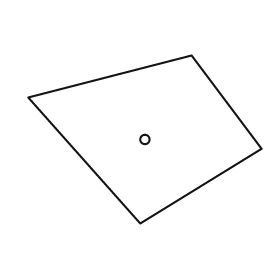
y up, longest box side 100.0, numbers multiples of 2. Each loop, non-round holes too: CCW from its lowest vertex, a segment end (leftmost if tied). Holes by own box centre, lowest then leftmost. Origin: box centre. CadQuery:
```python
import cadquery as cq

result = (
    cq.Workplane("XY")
    .moveTo(-2.0, -36.0)
    .lineTo(50.0, -4.0)
    .lineTo(20.0, 36.0)
    .lineTo(-50.0, 18.0)
    .close()
    .moveTo(0.0, 0.0)
    .circle(2.0)
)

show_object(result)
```